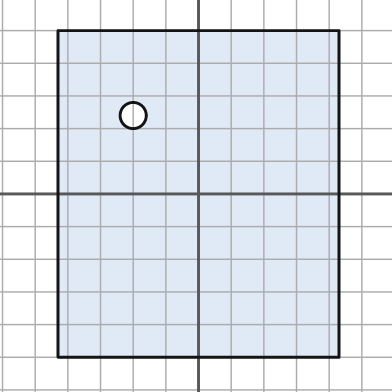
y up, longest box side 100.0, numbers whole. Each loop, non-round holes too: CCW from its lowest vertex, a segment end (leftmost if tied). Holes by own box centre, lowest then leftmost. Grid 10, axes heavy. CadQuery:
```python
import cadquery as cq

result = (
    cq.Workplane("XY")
    .moveTo(-43.0, -50.0)
    .lineTo(43.0, -50.0)
    .lineTo(43.0, 50.0)
    .lineTo(-43.0, 50.0)
    .close()
    .moveTo(-20.0, 24.0)
    .circle(4.0)
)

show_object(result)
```